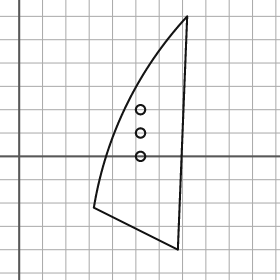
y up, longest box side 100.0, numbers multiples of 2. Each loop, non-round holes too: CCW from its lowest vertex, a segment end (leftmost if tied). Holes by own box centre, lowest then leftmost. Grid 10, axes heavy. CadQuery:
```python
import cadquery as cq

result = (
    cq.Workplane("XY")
    .moveTo(68.0, -40.0)
    .lineTo(72.0, 60.0)
    .threePointArc((46.0, 22.0), (32.0, -22.0))
    .close()
    .moveTo(52.0, 0.0)
    .circle(2.0)
    .moveTo(52.0, 10.0)
    .circle(2.0)
    .moveTo(52.0, 20.0)
    .circle(2.0)
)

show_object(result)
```